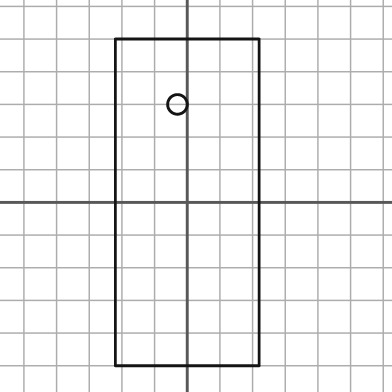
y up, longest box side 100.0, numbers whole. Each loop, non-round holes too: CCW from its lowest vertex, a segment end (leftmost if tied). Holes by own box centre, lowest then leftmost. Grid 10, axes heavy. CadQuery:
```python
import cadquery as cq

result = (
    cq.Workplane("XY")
    .moveTo(-22.0, -50.0)
    .lineTo(22.0, -50.0)
    .lineTo(22.0, 50.0)
    .lineTo(-22.0, 50.0)
    .close()
    .moveTo(-3.0, 30.0)
    .circle(3.0)
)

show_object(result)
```